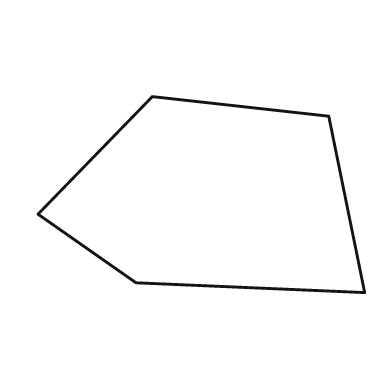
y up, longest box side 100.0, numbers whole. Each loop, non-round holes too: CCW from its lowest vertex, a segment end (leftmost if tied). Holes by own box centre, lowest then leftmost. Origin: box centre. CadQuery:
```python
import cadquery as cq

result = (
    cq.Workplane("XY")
    .moveTo(50.0, -30.0)
    .lineTo(39.0, 24.0)
    .lineTo(-15.0, 30.0)
    .lineTo(-50.0, -6.0)
    .lineTo(-20.0, -27.0)
    .close()
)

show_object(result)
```